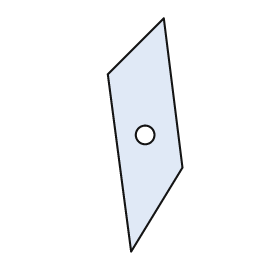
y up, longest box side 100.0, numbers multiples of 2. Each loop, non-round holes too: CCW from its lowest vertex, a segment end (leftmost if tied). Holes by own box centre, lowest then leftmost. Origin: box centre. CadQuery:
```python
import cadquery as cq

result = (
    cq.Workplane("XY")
    .moveTo(-6.0, -50.0)
    .lineTo(16.0, -14.0)
    .lineTo(8.0, 50.0)
    .lineTo(-16.0, 26.0)
    .close()
    .moveTo(0.0, 0.0)
    .circle(4.0)
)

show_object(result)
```